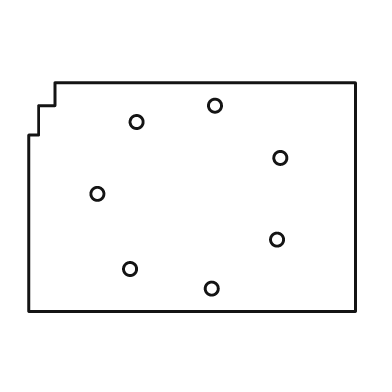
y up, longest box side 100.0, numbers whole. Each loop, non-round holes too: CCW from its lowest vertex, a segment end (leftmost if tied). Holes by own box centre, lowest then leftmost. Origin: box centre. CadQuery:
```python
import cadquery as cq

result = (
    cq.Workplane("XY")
    .moveTo(-50.0, -35.0)
    .lineTo(50.0, -35.0)
    .lineTo(50.0, 35.0)
    .lineTo(-42.0, 35.0)
    .lineTo(-42.0, 28.0)
    .lineTo(-47.0, 28.0)
    .lineTo(-47.0, 19.0)
    .lineTo(-50.0, 19.0)
    .close()
    .moveTo(6.0, -28.0)
    .circle(2.0)
    .moveTo(-19.0, -22.0)
    .circle(2.0)
    .moveTo(26.0, -13.0)
    .circle(2.0)
    .moveTo(-29.0, 1.0)
    .circle(2.0)
    .moveTo(27.0, 12.0)
    .circle(2.0)
    .moveTo(-17.0, 23.0)
    .circle(2.0)
    .moveTo(7.0, 28.0)
    .circle(2.0)
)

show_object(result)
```